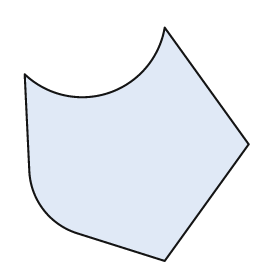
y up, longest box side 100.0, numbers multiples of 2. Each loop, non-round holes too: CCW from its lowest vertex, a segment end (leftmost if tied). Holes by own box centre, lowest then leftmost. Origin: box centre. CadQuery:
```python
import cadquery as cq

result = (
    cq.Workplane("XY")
    .moveTo(12.0, -50.0)
    .lineTo(48.0, 0.0)
    .lineTo(12.0, 50.0)
    .threePointArc((-12.0, 22.0), (-48.0, 30.0))
    .lineTo(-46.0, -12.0)
    .threePointArc((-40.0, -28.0), (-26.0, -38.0))
    .close()
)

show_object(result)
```